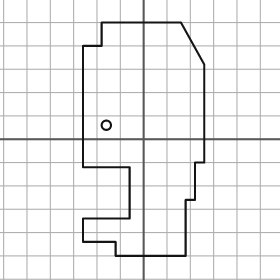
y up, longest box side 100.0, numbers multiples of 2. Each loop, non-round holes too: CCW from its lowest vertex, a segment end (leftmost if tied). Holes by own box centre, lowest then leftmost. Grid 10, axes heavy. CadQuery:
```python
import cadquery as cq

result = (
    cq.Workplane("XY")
    .moveTo(-12.0, -50.0)
    .lineTo(18.0, -50.0)
    .lineTo(18.0, -26.0)
    .lineTo(22.0, -26.0)
    .lineTo(22.0, -10.0)
    .lineTo(26.0, -10.0)
    .lineTo(26.0, 32.0)
    .lineTo(16.0, 50.0)
    .lineTo(-18.0, 50.0)
    .lineTo(-18.0, 40.0)
    .lineTo(-26.0, 40.0)
    .lineTo(-26.0, -12.0)
    .lineTo(-6.0, -12.0)
    .lineTo(-6.0, -34.0)
    .lineTo(-26.0, -34.0)
    .lineTo(-26.0, -44.0)
    .lineTo(-12.0, -44.0)
    .close()
    .moveTo(-16.0, 6.0)
    .circle(2.0)
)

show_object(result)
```